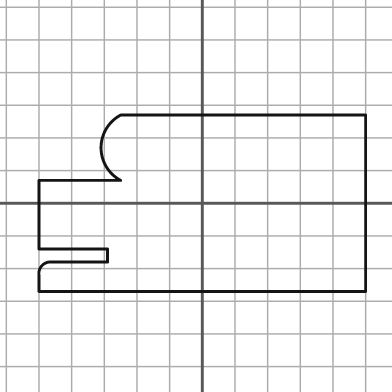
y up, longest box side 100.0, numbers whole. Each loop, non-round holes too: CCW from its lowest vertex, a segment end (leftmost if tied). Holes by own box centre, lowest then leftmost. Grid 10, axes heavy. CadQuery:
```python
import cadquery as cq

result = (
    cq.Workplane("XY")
    .moveTo(-50.0, -27.0)
    .lineTo(50.0, -27.0)
    .lineTo(50.0, 27.0)
    .lineTo(-25.0, 27.0)
    .threePointArc((-31.0, 17.0), (-25.0, 7.0))
    .lineTo(-50.0, 7.0)
    .lineTo(-50.0, -14.0)
    .lineTo(-29.0, -14.0)
    .lineTo(-29.0, -18.0)
    .lineTo(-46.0, -18.0)
    .threePointArc((-49.0, -19.0), (-50.0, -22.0))
    .close()
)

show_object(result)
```